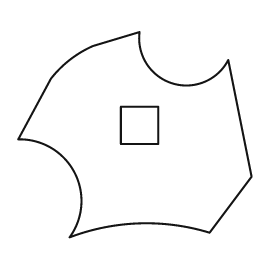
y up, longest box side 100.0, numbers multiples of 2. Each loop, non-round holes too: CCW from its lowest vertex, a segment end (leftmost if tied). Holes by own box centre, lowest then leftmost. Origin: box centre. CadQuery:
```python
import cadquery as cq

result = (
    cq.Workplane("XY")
    .moveTo(-28.0, -44.0)
    .threePointArc((2.0, -38.0), (32.0, -42.0))
    .lineTo(50.0, -18.0)
    .lineTo(40.0, 32.0)
    .threePointArc((16.0, 22.0), (2.0, 44.0))
    .lineTo(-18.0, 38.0)
    .threePointArc((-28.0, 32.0), (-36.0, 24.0))
    .lineTo(-50.0, -2.0)
    .threePointArc((-26.0, -16.0), (-28.0, -44.0))
    .close()
    .moveTo(-6.0, -4.0)
    .lineTo(10.0, -4.0)
    .lineTo(10.0, 12.0)
    .lineTo(-6.0, 12.0)
    .close()
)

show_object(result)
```